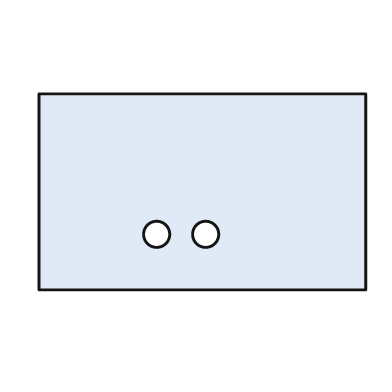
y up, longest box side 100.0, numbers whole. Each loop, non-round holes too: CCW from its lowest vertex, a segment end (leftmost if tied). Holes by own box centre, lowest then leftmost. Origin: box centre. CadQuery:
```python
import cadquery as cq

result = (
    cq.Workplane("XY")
    .moveTo(-50.0, -30.0)
    .lineTo(50.0, -30.0)
    .lineTo(50.0, 30.0)
    .lineTo(-50.0, 30.0)
    .close()
    .moveTo(-14.0, -13.0)
    .circle(4.0)
    .moveTo(1.0, -13.0)
    .circle(4.0)
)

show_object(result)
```